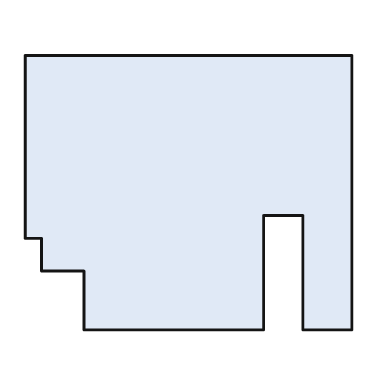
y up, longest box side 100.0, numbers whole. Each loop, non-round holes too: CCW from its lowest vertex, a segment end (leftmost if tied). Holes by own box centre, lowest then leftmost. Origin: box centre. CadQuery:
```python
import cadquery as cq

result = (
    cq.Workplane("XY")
    .moveTo(-32.0, -42.0)
    .lineTo(23.0, -42.0)
    .lineTo(23.0, -7.0)
    .lineTo(35.0, -7.0)
    .lineTo(35.0, -42.0)
    .lineTo(50.0, -42.0)
    .lineTo(50.0, 42.0)
    .lineTo(-50.0, 42.0)
    .lineTo(-50.0, -14.0)
    .lineTo(-45.0, -14.0)
    .lineTo(-45.0, -24.0)
    .lineTo(-32.0, -24.0)
    .close()
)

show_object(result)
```